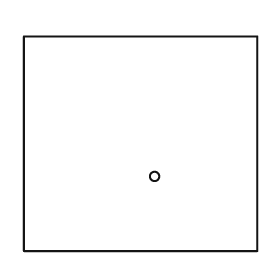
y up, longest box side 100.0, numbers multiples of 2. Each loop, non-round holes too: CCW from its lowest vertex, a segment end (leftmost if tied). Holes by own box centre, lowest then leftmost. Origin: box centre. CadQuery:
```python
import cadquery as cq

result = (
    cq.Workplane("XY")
    .moveTo(-50.0, -46.0)
    .lineTo(50.0, -46.0)
    .lineTo(50.0, 46.0)
    .lineTo(-50.0, 46.0)
    .close()
    .moveTo(6.0, -14.0)
    .circle(2.0)
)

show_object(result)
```